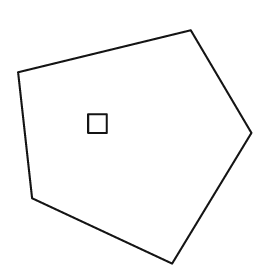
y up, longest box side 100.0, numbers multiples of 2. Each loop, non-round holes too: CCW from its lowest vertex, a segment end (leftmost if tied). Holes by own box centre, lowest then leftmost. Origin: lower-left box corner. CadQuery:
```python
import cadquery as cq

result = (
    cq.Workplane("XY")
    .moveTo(66.0, 0.0)
    .lineTo(100.0, 56.0)
    .lineTo(74.0, 100.0)
    .lineTo(0.0, 82.0)
    .lineTo(6.0, 28.0)
    .close()
    .moveTo(30.0, 56.0)
    .lineTo(38.0, 56.0)
    .lineTo(38.0, 64.0)
    .lineTo(30.0, 64.0)
    .close()
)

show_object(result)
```